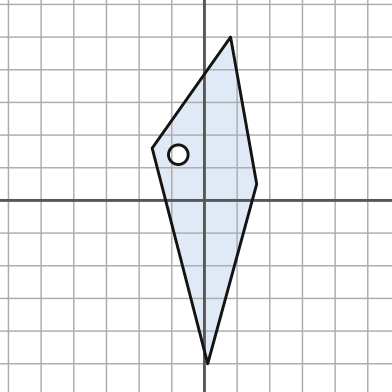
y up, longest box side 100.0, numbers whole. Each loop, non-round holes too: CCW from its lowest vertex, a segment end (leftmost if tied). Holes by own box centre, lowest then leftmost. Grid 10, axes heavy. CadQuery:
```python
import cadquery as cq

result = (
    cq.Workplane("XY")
    .moveTo(1.0, -50.0)
    .lineTo(16.0, 5.0)
    .lineTo(8.0, 50.0)
    .lineTo(-16.0, 16.0)
    .close()
    .moveTo(-8.0, 14.0)
    .circle(3.0)
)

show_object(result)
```